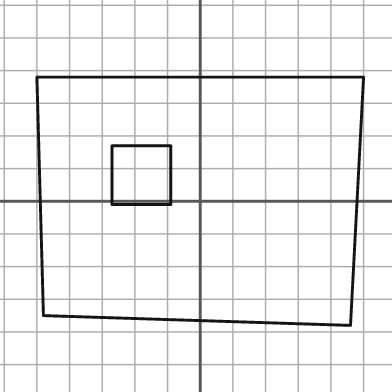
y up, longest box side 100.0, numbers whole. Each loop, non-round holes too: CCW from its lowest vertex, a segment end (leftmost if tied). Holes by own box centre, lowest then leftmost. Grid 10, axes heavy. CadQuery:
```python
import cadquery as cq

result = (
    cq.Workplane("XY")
    .moveTo(46.0, -38.0)
    .lineTo(50.0, 38.0)
    .lineTo(-50.0, 38.0)
    .lineTo(-48.0, -35.0)
    .close()
    .moveTo(-27.0, -1.0)
    .lineTo(-9.0, -1.0)
    .lineTo(-9.0, 17.0)
    .lineTo(-27.0, 17.0)
    .close()
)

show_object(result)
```